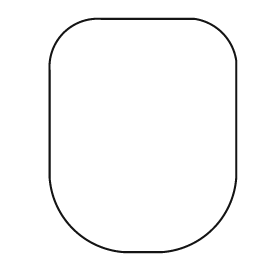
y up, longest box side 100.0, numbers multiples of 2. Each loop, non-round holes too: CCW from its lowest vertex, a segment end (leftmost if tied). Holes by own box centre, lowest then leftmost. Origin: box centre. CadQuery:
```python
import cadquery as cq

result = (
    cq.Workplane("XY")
    .moveTo(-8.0, -50.0)
    .lineTo(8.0, -50.0)
    .threePointArc((30.0, -40.0), (40.0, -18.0))
    .lineTo(40.0, 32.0)
    .threePointArc((34.0, 44.0), (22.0, 50.0))
    .lineTo(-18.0, 50.0)
    .threePointArc((-34.0, 44.0), (-40.0, 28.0))
    .lineTo(-40.0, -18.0)
    .threePointArc((-30.0, -40.0), (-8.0, -50.0))
    .close()
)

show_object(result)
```